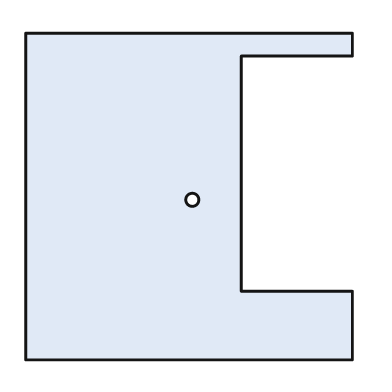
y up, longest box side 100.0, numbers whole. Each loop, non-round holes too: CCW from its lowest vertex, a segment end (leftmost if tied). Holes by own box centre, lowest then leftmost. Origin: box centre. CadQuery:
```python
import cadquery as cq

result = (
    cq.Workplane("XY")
    .moveTo(-50.0, -50.0)
    .lineTo(50.0, -50.0)
    .lineTo(50.0, -29.0)
    .lineTo(16.0, -29.0)
    .lineTo(16.0, 43.0)
    .lineTo(50.0, 43.0)
    .lineTo(50.0, 50.0)
    .lineTo(-50.0, 50.0)
    .close()
    .moveTo(1.0, -1.0)
    .circle(2.0)
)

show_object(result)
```